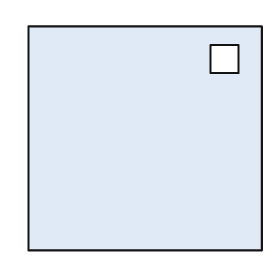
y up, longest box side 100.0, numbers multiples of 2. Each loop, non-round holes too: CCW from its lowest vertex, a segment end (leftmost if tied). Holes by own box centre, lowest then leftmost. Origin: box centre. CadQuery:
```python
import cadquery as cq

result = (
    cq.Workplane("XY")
    .moveTo(-50.0, -48.0)
    .lineTo(50.0, -48.0)
    .lineTo(50.0, 48.0)
    .lineTo(-50.0, 48.0)
    .close()
    .moveTo(28.0, 28.0)
    .lineTo(40.0, 28.0)
    .lineTo(40.0, 40.0)
    .lineTo(28.0, 40.0)
    .close()
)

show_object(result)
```